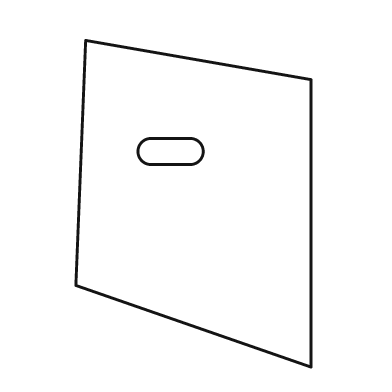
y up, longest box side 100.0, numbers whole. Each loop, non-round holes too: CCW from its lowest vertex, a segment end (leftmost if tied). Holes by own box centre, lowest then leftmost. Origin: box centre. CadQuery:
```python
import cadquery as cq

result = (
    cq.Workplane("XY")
    .moveTo(36.0, -50.0)
    .lineTo(36.0, 38.0)
    .lineTo(-33.0, 50.0)
    .lineTo(-36.0, -25.0)
    .close()
    .moveTo(-13.0, 12.0)
    .lineTo(-1.0, 12.0)
    .threePointArc((3.0, 16.0), (-1.0, 20.0))
    .lineTo(-13.0, 20.0)
    .threePointArc((-17.0, 16.0), (-13.0, 12.0))
    .close()
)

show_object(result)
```